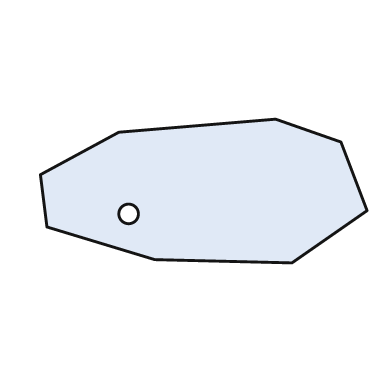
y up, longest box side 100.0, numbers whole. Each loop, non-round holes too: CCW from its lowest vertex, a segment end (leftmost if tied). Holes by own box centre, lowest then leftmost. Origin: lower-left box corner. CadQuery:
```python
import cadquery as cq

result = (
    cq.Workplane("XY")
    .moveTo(77.0, 0.0)
    .lineTo(100.0, 16.0)
    .lineTo(92.0, 37.0)
    .lineTo(72.0, 44.0)
    .lineTo(24.0, 40.0)
    .lineTo(0.0, 27.0)
    .lineTo(2.0, 11.0)
    .lineTo(35.0, 1.0)
    .close()
    .moveTo(27.0, 15.0)
    .circle(3.0)
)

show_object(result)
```